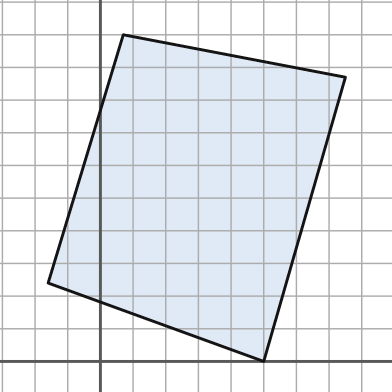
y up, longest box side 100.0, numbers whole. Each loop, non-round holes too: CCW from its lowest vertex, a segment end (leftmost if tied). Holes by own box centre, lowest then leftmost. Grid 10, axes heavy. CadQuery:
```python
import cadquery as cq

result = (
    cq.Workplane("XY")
    .moveTo(50.0, 0.0)
    .lineTo(75.0, 87.0)
    .lineTo(7.0, 100.0)
    .lineTo(-16.0, 24.0)
    .close()
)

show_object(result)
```